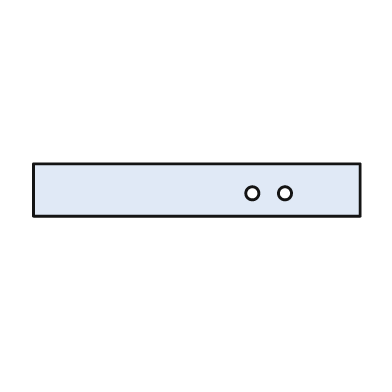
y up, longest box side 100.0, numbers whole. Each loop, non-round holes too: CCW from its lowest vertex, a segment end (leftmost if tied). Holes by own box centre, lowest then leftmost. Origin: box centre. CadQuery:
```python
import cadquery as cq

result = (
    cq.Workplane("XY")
    .moveTo(-50.0, -8.0)
    .lineTo(50.0, -8.0)
    .lineTo(50.0, 8.0)
    .lineTo(-50.0, 8.0)
    .close()
    .moveTo(17.0, -1.0)
    .circle(2.0)
    .moveTo(27.0, -1.0)
    .circle(2.0)
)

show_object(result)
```